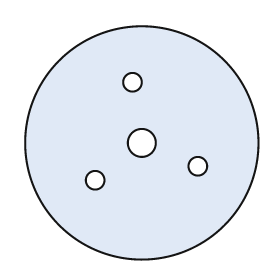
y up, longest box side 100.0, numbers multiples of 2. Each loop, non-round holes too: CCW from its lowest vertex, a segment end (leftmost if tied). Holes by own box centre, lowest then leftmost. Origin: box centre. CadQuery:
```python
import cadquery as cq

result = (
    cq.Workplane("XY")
    .moveTo(0.0, 0.0)
    .circle(50.0)
    .moveTo(-20.0, -16.0)
    .circle(4.0)
    .moveTo(24.0, -10.0)
    .circle(4.0)
    .moveTo(0.0, 0.0)
    .circle(6.0)
    .moveTo(-4.0, 26.0)
    .circle(4.0)
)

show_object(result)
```